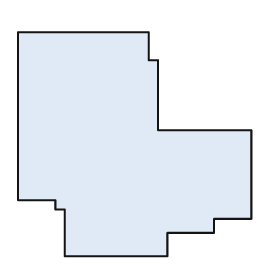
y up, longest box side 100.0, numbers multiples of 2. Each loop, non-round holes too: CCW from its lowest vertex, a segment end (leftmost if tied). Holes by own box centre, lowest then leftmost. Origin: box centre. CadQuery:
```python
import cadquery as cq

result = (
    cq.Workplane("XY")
    .moveTo(-30.0, -48.0)
    .lineTo(14.0, -48.0)
    .lineTo(14.0, -38.0)
    .lineTo(34.0, -38.0)
    .lineTo(34.0, -32.0)
    .lineTo(50.0, -32.0)
    .lineTo(50.0, 6.0)
    .lineTo(10.0, 6.0)
    .lineTo(10.0, 36.0)
    .lineTo(6.0, 36.0)
    .lineTo(6.0, 48.0)
    .lineTo(-50.0, 48.0)
    .lineTo(-50.0, -24.0)
    .lineTo(-34.0, -24.0)
    .lineTo(-34.0, -28.0)
    .lineTo(-30.0, -28.0)
    .close()
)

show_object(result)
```